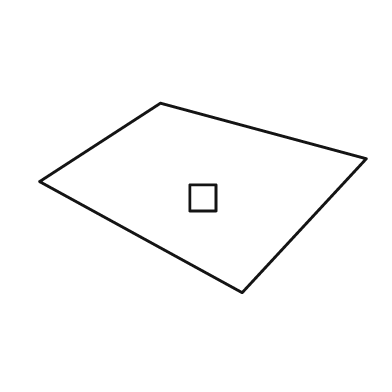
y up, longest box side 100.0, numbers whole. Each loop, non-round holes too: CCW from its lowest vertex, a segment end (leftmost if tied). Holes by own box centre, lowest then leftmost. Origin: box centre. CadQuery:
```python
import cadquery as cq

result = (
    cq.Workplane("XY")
    .moveTo(12.0, -29.0)
    .lineTo(50.0, 12.0)
    .lineTo(-13.0, 29.0)
    .lineTo(-50.0, 5.0)
    .close()
    .moveTo(-4.0, -4.0)
    .lineTo(4.0, -4.0)
    .lineTo(4.0, 4.0)
    .lineTo(-4.0, 4.0)
    .close()
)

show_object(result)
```